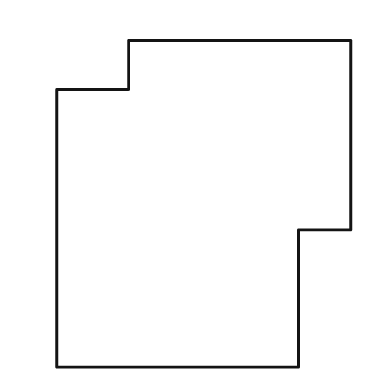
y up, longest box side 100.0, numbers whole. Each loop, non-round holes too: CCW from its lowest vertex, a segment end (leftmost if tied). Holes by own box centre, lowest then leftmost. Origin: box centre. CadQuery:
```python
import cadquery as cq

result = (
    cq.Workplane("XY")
    .moveTo(-45.0, -50.0)
    .lineTo(29.0, -50.0)
    .lineTo(29.0, -8.0)
    .lineTo(45.0, -8.0)
    .lineTo(45.0, 50.0)
    .lineTo(-23.0, 50.0)
    .lineTo(-23.0, 35.0)
    .lineTo(-45.0, 35.0)
    .close()
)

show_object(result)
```